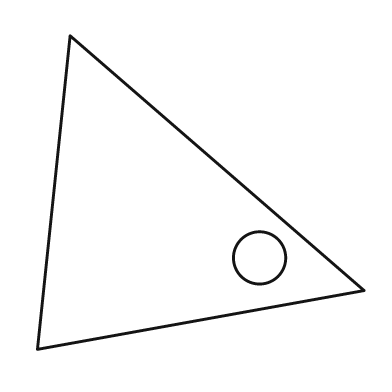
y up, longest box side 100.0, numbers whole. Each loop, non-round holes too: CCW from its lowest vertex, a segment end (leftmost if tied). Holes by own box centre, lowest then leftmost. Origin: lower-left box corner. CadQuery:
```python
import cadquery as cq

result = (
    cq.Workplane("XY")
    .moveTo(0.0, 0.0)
    .lineTo(100.0, 18.0)
    .lineTo(10.0, 96.0)
    .close()
    .moveTo(68.0, 28.0)
    .circle(8.0)
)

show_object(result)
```